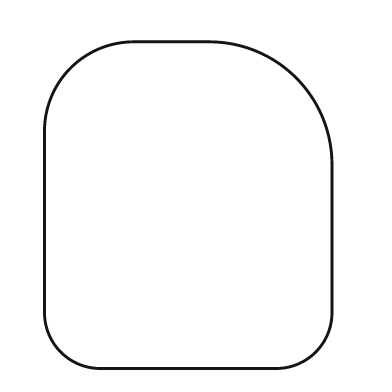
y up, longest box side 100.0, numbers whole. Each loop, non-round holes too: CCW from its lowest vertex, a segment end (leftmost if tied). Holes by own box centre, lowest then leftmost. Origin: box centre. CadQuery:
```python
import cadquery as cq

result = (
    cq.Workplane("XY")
    .moveTo(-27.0, -50.0)
    .lineTo(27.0, -50.0)
    .threePointArc((39.0, -45.0), (44.0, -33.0))
    .lineTo(44.0, 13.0)
    .threePointArc((33.0, 39.0), (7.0, 50.0))
    .lineTo(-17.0, 50.0)
    .threePointArc((-36.0, 42.0), (-44.0, 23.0))
    .lineTo(-44.0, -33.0)
    .threePointArc((-39.0, -45.0), (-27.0, -50.0))
    .close()
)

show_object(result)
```